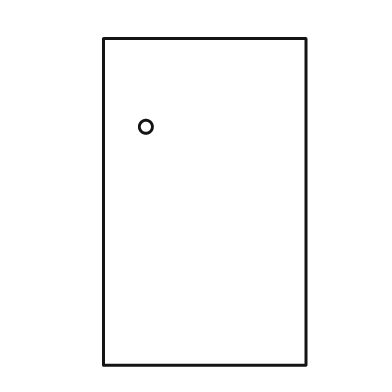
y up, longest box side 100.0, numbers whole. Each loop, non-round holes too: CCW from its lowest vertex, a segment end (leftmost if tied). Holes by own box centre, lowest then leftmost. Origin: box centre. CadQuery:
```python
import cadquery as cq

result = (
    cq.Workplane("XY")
    .moveTo(-31.0, -50.0)
    .lineTo(31.0, -50.0)
    .lineTo(31.0, 50.0)
    .lineTo(-31.0, 50.0)
    .close()
    .moveTo(-18.0, 23.0)
    .circle(2.0)
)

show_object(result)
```